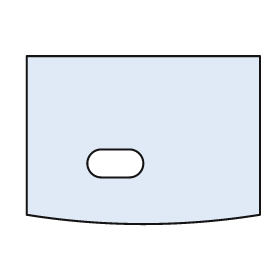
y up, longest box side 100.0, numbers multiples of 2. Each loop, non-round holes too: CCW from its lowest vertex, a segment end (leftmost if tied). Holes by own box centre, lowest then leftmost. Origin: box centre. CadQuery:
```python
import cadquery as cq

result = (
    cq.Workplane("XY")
    .moveTo(-50.0, -32.0)
    .threePointArc((0.0, -36.0), (50.0, -32.0))
    .lineTo(50.0, 36.0)
    .lineTo(-50.0, 36.0)
    .close()
    .moveTo(-18.0, -16.0)
    .lineTo(-6.0, -16.0)
    .threePointArc((0.0, -10.0), (-6.0, -4.0))
    .lineTo(-18.0, -4.0)
    .threePointArc((-24.0, -10.0), (-18.0, -16.0))
    .close()
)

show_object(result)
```